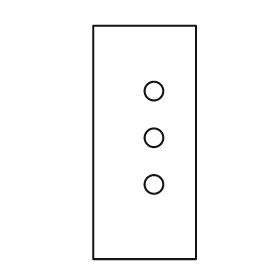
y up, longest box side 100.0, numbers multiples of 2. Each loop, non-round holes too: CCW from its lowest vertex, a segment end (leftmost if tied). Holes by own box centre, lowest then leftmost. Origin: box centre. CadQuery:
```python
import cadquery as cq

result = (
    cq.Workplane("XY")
    .moveTo(-22.0, -50.0)
    .lineTo(22.0, -50.0)
    .lineTo(22.0, 50.0)
    .lineTo(-22.0, 50.0)
    .close()
    .moveTo(4.0, -18.0)
    .circle(4.0)
    .moveTo(4.0, 2.0)
    .circle(4.0)
    .moveTo(4.0, 22.0)
    .circle(4.0)
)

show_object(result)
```